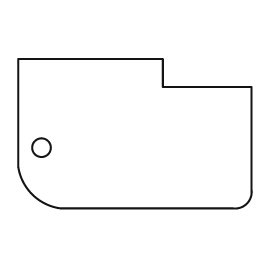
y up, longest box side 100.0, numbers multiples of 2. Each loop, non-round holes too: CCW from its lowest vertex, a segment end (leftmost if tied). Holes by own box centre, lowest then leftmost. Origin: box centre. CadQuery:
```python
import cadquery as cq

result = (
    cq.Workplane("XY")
    .moveTo(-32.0, -32.0)
    .lineTo(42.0, -32.0)
    .threePointArc((48.0, -30.0), (50.0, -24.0))
    .lineTo(50.0, 20.0)
    .lineTo(12.0, 20.0)
    .lineTo(12.0, 32.0)
    .lineTo(-50.0, 32.0)
    .lineTo(-50.0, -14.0)
    .threePointArc((-44.0, -26.0), (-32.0, -32.0))
    .close()
    .moveTo(-40.0, -6.0)
    .circle(4.0)
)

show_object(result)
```